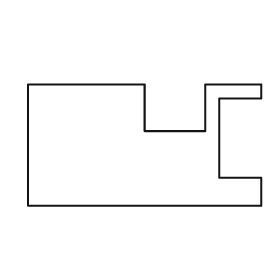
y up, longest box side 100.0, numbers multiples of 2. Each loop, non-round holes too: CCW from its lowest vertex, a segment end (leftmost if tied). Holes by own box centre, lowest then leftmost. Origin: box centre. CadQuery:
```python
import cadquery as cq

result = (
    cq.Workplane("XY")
    .moveTo(-50.0, -26.0)
    .lineTo(50.0, -26.0)
    .lineTo(50.0, -14.0)
    .lineTo(32.0, -14.0)
    .lineTo(32.0, 20.0)
    .lineTo(50.0, 20.0)
    .lineTo(50.0, 26.0)
    .lineTo(26.0, 26.0)
    .lineTo(26.0, 6.0)
    .lineTo(0.0, 6.0)
    .lineTo(0.0, 26.0)
    .lineTo(-50.0, 26.0)
    .close()
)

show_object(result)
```